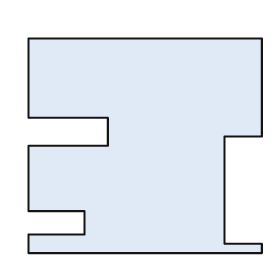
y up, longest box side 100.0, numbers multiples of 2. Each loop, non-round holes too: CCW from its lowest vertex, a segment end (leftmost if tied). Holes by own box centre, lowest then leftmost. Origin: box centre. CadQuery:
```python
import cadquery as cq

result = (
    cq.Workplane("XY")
    .moveTo(-50.0, -46.0)
    .lineTo(50.0, -46.0)
    .lineTo(50.0, -42.0)
    .lineTo(34.0, -42.0)
    .lineTo(34.0, 4.0)
    .lineTo(50.0, 4.0)
    .lineTo(50.0, 46.0)
    .lineTo(-50.0, 46.0)
    .lineTo(-50.0, 12.0)
    .lineTo(-16.0, 12.0)
    .lineTo(-16.0, 0.0)
    .lineTo(-50.0, 0.0)
    .lineTo(-50.0, -28.0)
    .lineTo(-26.0, -28.0)
    .lineTo(-26.0, -38.0)
    .lineTo(-50.0, -38.0)
    .close()
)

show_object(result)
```